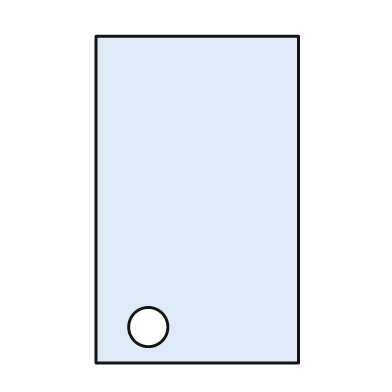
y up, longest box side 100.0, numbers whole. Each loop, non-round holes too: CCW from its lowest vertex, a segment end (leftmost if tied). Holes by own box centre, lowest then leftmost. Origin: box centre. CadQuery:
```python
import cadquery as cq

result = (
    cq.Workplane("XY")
    .moveTo(-31.0, -50.0)
    .lineTo(31.0, -50.0)
    .lineTo(31.0, 50.0)
    .lineTo(-31.0, 50.0)
    .close()
    .moveTo(-15.0, -39.0)
    .circle(6.0)
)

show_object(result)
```